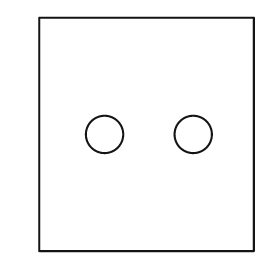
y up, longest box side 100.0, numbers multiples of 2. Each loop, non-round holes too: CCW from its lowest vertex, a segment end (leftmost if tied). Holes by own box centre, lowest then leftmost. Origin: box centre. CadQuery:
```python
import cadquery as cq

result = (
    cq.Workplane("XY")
    .moveTo(-46.0, -50.0)
    .lineTo(46.0, -50.0)
    .lineTo(46.0, 50.0)
    .lineTo(-46.0, 50.0)
    .close()
    .moveTo(-18.0, 0.0)
    .circle(8.0)
    .moveTo(20.0, 0.0)
    .circle(8.0)
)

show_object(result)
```